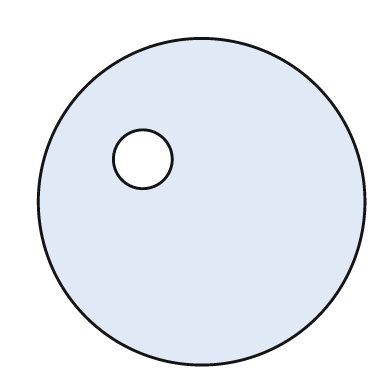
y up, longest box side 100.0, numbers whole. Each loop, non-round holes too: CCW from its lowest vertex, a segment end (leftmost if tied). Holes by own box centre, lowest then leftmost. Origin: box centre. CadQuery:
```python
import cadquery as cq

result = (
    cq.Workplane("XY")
    .moveTo(0.0, 0.0)
    .circle(50.0)
    .moveTo(-18.0, 13.0)
    .circle(9.0)
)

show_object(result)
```